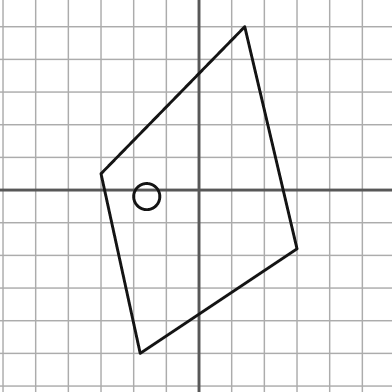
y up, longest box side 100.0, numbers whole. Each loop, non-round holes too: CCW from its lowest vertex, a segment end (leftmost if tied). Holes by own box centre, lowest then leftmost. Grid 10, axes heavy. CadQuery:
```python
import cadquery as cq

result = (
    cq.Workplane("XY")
    .moveTo(-18.0, -50.0)
    .lineTo(30.0, -18.0)
    .lineTo(14.0, 50.0)
    .lineTo(-30.0, 5.0)
    .close()
    .moveTo(-16.0, -2.0)
    .circle(4.0)
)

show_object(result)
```